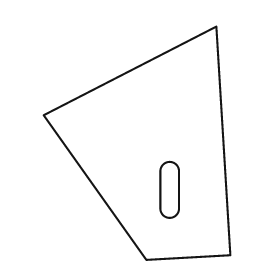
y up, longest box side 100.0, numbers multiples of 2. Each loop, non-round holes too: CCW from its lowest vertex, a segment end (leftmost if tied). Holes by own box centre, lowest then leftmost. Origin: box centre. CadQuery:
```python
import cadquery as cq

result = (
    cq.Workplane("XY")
    .moveTo(4.0, -50.0)
    .lineTo(40.0, -48.0)
    .lineTo(34.0, 50.0)
    .lineTo(-40.0, 12.0)
    .close()
    .moveTo(10.0, -28.0)
    .threePointArc((14.0, -32.0), (18.0, -28.0))
    .lineTo(18.0, -12.0)
    .threePointArc((14.0, -8.0), (10.0, -12.0))
    .close()
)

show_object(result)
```